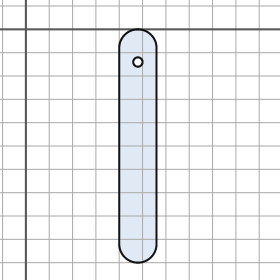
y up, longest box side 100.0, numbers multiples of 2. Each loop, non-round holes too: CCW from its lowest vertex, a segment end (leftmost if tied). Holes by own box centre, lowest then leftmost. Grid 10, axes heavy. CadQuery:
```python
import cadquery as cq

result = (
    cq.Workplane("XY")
    .moveTo(40.0, -92.0)
    .threePointArc((48.0, -100.0), (56.0, -92.0))
    .lineTo(56.0, -8.0)
    .threePointArc((48.0, 0.0), (40.0, -8.0))
    .close()
    .moveTo(48.0, -14.0)
    .circle(2.0)
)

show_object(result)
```